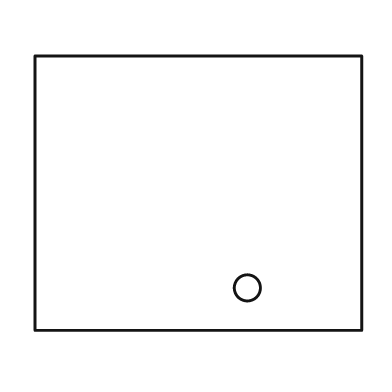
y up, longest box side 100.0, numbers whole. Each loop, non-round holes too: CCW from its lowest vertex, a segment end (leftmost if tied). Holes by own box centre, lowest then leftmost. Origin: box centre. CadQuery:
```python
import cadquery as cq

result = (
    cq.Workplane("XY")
    .moveTo(-50.0, -42.0)
    .lineTo(50.0, -42.0)
    .lineTo(50.0, 42.0)
    .lineTo(-50.0, 42.0)
    .close()
    .moveTo(15.0, -29.0)
    .circle(4.0)
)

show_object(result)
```